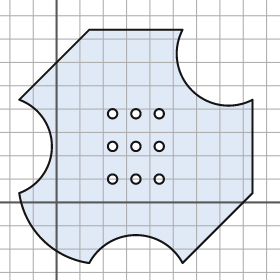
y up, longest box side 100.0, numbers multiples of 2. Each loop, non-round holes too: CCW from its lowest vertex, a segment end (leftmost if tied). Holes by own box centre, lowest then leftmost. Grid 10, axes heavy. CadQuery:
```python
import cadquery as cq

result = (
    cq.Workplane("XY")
    .moveTo(14.0, -26.0)
    .threePointArc((34.0, -14.0), (54.0, -26.0))
    .lineTo(84.0, 4.0)
    .lineTo(84.0, 44.0)
    .threePointArc((58.0, 48.0), (54.0, 74.0))
    .lineTo(14.0, 74.0)
    .lineTo(-16.0, 44.0)
    .threePointArc((-2.0, 24.0), (-16.0, 4.0))
    .threePointArc((-6.0, -16.0), (14.0, -26.0))
    .close()
    .moveTo(24.0, 10.0)
    .circle(2.0)
    .moveTo(34.0, 10.0)
    .circle(2.0)
    .moveTo(44.0, 10.0)
    .circle(2.0)
    .moveTo(24.0, 24.0)
    .circle(2.0)
    .moveTo(34.0, 24.0)
    .circle(2.0)
    .moveTo(44.0, 24.0)
    .circle(2.0)
    .moveTo(24.0, 38.0)
    .circle(2.0)
    .moveTo(34.0, 38.0)
    .circle(2.0)
    .moveTo(44.0, 38.0)
    .circle(2.0)
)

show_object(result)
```